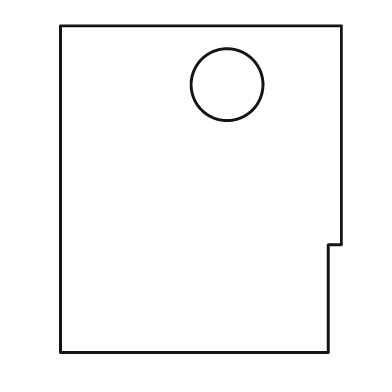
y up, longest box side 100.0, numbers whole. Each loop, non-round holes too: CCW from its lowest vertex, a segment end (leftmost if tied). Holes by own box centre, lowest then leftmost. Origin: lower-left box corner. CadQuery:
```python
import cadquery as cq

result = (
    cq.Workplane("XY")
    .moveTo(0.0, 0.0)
    .lineTo(82.0, 0.0)
    .lineTo(82.0, 33.0)
    .lineTo(86.0, 33.0)
    .lineTo(86.0, 100.0)
    .lineTo(0.0, 100.0)
    .close()
    .moveTo(51.0, 82.0)
    .circle(11.0)
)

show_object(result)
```